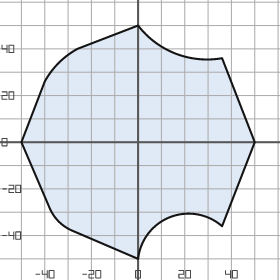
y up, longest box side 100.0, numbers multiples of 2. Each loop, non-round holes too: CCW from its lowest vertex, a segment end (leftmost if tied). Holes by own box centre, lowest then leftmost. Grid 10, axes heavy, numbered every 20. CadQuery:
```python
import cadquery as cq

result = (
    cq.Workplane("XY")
    .moveTo(0.0, -50.0)
    .threePointArc((14.0, -32.0), (36.0, -36.0))
    .lineTo(50.0, 0.0)
    .lineTo(36.0, 36.0)
    .threePointArc((16.0, 38.0), (0.0, 50.0))
    .lineTo(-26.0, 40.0)
    .threePointArc((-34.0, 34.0), (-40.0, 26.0))
    .lineTo(-50.0, 0.0)
    .lineTo(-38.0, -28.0)
    .threePointArc((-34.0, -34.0), (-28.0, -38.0))
    .close()
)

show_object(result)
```